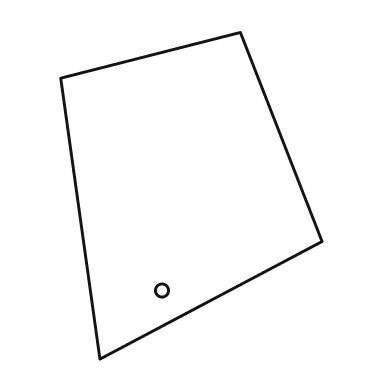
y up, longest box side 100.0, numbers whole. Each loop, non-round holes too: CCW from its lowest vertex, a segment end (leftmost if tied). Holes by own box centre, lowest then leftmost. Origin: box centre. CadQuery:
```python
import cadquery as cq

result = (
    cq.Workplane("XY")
    .moveTo(-28.0, -50.0)
    .lineTo(40.0, -14.0)
    .lineTo(15.0, 50.0)
    .lineTo(-40.0, 36.0)
    .close()
    .moveTo(-9.0, -29.0)
    .circle(2.0)
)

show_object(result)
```